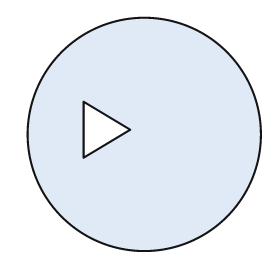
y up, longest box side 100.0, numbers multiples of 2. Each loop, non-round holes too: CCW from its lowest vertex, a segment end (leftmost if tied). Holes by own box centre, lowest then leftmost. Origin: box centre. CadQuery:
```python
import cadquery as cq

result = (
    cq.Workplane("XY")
    .moveTo(0.0, 0.0)
    .circle(50.0)
    .moveTo(-26.0, -10.0)
    .lineTo(-6.0, 2.0)
    .lineTo(-26.0, 14.0)
    .close()
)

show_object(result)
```